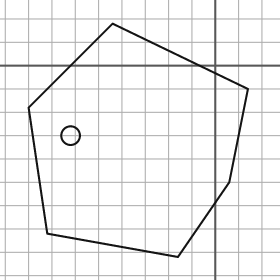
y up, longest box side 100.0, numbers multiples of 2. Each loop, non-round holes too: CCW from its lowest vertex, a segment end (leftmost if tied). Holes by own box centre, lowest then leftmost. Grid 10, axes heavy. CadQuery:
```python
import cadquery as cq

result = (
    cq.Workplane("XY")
    .moveTo(-16.0, -82.0)
    .lineTo(6.0, -50.0)
    .lineTo(14.0, -10.0)
    .lineTo(-44.0, 18.0)
    .lineTo(-80.0, -18.0)
    .lineTo(-72.0, -72.0)
    .close()
    .moveTo(-62.0, -30.0)
    .circle(4.0)
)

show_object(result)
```